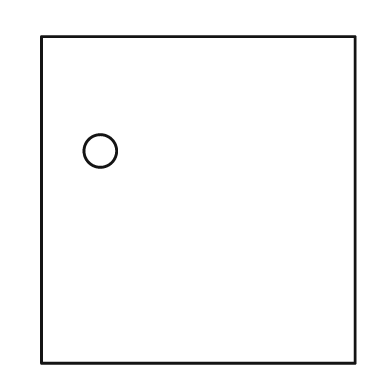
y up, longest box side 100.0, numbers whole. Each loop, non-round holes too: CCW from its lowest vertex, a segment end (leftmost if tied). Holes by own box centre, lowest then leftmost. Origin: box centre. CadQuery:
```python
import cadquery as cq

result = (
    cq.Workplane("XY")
    .moveTo(-48.0, -50.0)
    .lineTo(48.0, -50.0)
    .lineTo(48.0, 50.0)
    .lineTo(-48.0, 50.0)
    .close()
    .moveTo(-30.0, 15.0)
    .circle(5.0)
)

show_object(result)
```